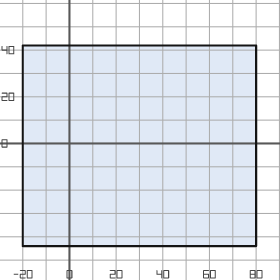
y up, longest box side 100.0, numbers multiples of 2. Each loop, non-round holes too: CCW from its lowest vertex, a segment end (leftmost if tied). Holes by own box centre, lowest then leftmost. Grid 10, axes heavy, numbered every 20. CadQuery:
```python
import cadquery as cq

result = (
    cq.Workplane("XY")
    .moveTo(-20.0, -44.0)
    .lineTo(80.0, -44.0)
    .lineTo(80.0, 42.0)
    .lineTo(-20.0, 42.0)
    .close()
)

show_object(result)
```